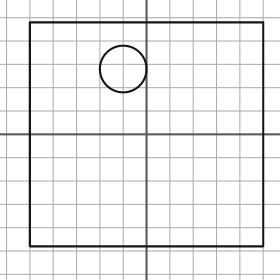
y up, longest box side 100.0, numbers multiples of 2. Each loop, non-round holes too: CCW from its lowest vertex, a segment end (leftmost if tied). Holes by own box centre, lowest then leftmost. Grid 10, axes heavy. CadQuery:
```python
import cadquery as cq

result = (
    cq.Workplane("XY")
    .moveTo(-50.0, -48.0)
    .lineTo(50.0, -48.0)
    .lineTo(50.0, 48.0)
    .lineTo(-50.0, 48.0)
    .close()
    .moveTo(-10.0, 28.0)
    .circle(10.0)
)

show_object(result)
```